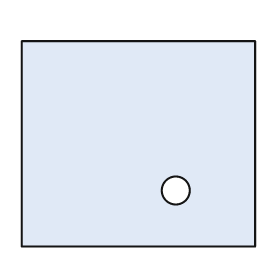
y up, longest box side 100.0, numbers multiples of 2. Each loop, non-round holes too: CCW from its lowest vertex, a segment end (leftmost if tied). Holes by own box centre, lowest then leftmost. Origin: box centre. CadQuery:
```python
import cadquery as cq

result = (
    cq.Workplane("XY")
    .moveTo(-50.0, -44.0)
    .lineTo(50.0, -44.0)
    .lineTo(50.0, 44.0)
    .lineTo(-50.0, 44.0)
    .close()
    .moveTo(16.0, -20.0)
    .circle(6.0)
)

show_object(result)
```